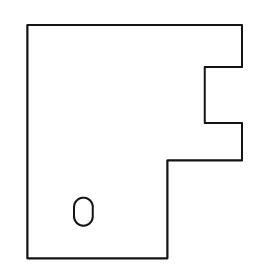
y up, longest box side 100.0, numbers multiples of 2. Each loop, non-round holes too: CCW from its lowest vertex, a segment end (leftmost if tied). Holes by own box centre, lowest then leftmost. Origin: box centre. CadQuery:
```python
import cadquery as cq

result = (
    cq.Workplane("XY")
    .moveTo(-46.0, -50.0)
    .lineTo(14.0, -50.0)
    .lineTo(14.0, -8.0)
    .lineTo(46.0, -8.0)
    .lineTo(46.0, 8.0)
    .lineTo(30.0, 8.0)
    .lineTo(30.0, 32.0)
    .lineTo(46.0, 32.0)
    .lineTo(46.0, 50.0)
    .lineTo(-46.0, 50.0)
    .close()
    .moveTo(-26.0, -32.0)
    .threePointArc((-22.0, -36.0), (-18.0, -32.0))
    .lineTo(-18.0, -28.0)
    .threePointArc((-22.0, -24.0), (-26.0, -28.0))
    .close()
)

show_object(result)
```